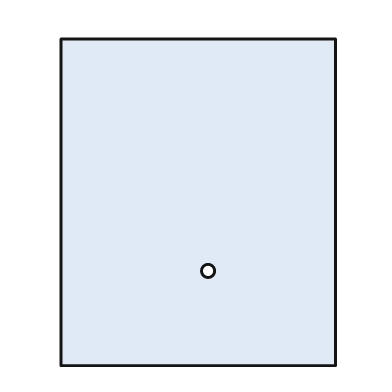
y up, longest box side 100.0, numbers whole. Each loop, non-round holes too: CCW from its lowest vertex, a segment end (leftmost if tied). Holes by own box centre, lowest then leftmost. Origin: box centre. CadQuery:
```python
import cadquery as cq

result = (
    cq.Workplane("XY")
    .moveTo(-42.0, -50.0)
    .lineTo(42.0, -50.0)
    .lineTo(42.0, 50.0)
    .lineTo(-42.0, 50.0)
    .close()
    .moveTo(3.0, -21.0)
    .circle(2.0)
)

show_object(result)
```